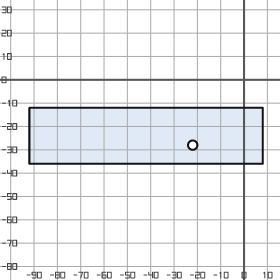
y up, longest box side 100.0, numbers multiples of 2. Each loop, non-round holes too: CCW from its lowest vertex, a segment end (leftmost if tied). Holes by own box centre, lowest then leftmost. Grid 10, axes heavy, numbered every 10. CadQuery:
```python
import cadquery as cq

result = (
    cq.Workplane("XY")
    .moveTo(-92.0, -36.0)
    .lineTo(8.0, -36.0)
    .lineTo(8.0, -12.0)
    .lineTo(-92.0, -12.0)
    .close()
    .moveTo(-22.0, -28.0)
    .circle(2.0)
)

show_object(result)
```